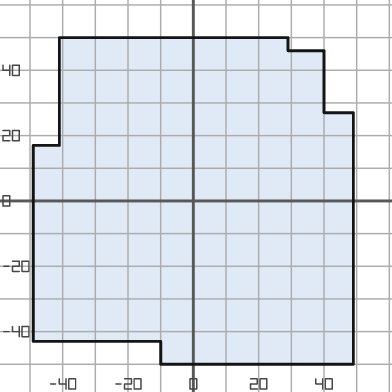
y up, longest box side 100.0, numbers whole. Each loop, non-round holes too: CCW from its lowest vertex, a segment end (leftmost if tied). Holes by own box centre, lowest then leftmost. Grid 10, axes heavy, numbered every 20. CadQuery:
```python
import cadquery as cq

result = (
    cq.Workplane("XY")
    .moveTo(-10.0, -50.0)
    .lineTo(49.0, -50.0)
    .lineTo(49.0, 27.0)
    .lineTo(40.0, 27.0)
    .lineTo(40.0, 46.0)
    .lineTo(29.0, 46.0)
    .lineTo(29.0, 50.0)
    .lineTo(-41.0, 50.0)
    .lineTo(-41.0, 17.0)
    .lineTo(-49.0, 17.0)
    .lineTo(-49.0, -43.0)
    .lineTo(-10.0, -43.0)
    .close()
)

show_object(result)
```